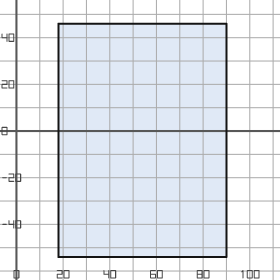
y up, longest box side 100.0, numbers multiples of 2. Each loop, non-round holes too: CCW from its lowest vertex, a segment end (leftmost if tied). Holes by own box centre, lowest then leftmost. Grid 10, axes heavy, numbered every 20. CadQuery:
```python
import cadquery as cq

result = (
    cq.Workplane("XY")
    .moveTo(18.0, -54.0)
    .lineTo(90.0, -54.0)
    .lineTo(90.0, 46.0)
    .lineTo(18.0, 46.0)
    .close()
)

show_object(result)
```